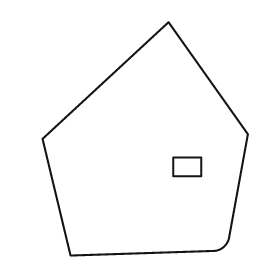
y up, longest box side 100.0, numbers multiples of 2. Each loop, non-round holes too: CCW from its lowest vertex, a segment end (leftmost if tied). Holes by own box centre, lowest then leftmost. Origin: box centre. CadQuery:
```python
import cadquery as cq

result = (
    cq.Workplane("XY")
    .moveTo(-32.0, -50.0)
    .lineTo(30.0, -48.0)
    .threePointArc((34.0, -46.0), (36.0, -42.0))
    .lineTo(44.0, 2.0)
    .lineTo(10.0, 50.0)
    .lineTo(-44.0, 0.0)
    .close()
    .moveTo(12.0, -16.0)
    .lineTo(24.0, -16.0)
    .lineTo(24.0, -8.0)
    .lineTo(12.0, -8.0)
    .close()
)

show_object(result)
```